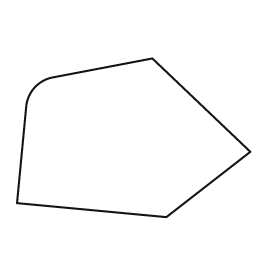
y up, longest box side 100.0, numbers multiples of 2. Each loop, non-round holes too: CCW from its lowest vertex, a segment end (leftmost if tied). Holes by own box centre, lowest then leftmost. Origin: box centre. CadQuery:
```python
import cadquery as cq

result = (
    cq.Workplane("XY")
    .moveTo(14.0, -34.0)
    .lineTo(50.0, -6.0)
    .lineTo(8.0, 34.0)
    .lineTo(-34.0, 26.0)
    .threePointArc((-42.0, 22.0), (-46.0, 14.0))
    .lineTo(-50.0, -28.0)
    .close()
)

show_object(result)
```